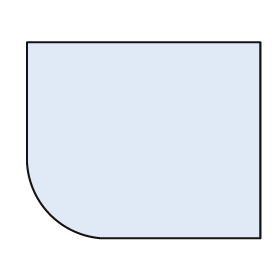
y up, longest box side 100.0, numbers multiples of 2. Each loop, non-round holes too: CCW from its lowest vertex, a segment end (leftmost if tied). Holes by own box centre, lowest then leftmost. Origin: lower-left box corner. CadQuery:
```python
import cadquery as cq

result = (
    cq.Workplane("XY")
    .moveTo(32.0, 0.0)
    .lineTo(100.0, 0.0)
    .lineTo(100.0, 84.0)
    .lineTo(0.0, 84.0)
    .lineTo(0.0, 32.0)
    .threePointArc((10.0, 10.0), (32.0, 0.0))
    .close()
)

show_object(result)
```